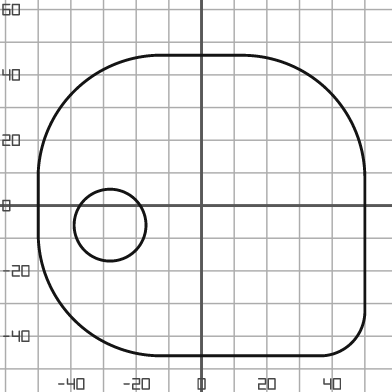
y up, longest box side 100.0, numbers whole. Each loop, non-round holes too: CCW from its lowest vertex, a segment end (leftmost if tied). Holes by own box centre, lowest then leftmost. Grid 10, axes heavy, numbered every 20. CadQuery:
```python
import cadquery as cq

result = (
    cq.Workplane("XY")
    .moveTo(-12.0, -46.0)
    .lineTo(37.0, -46.0)
    .threePointArc((46.0, -42.0), (50.0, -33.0))
    .lineTo(50.0, 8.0)
    .threePointArc((39.0, 35.0), (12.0, 46.0))
    .lineTo(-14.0, 46.0)
    .threePointArc((-39.0, 35.0), (-50.0, 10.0))
    .lineTo(-50.0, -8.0)
    .threePointArc((-39.0, -35.0), (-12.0, -46.0))
    .close()
    .moveTo(-28.0, -6.0)
    .circle(11.0)
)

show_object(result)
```